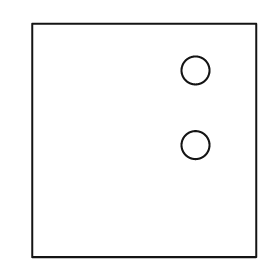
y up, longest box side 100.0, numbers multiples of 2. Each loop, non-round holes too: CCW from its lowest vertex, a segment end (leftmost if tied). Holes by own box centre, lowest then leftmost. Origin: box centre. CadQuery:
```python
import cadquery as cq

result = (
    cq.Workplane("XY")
    .moveTo(-48.0, -50.0)
    .lineTo(48.0, -50.0)
    .lineTo(48.0, 50.0)
    .lineTo(-48.0, 50.0)
    .close()
    .moveTo(22.0, -2.0)
    .circle(6.0)
    .moveTo(22.0, 30.0)
    .circle(6.0)
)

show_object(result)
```